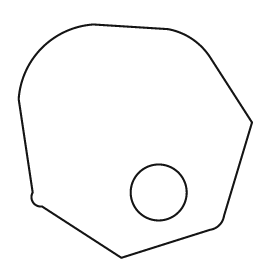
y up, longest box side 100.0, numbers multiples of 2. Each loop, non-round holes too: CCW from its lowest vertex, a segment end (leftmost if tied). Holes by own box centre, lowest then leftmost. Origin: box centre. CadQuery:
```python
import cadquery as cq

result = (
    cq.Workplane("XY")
    .moveTo(-6.0, -50.0)
    .lineTo(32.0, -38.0)
    .threePointArc((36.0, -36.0), (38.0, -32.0))
    .lineTo(50.0, 8.0)
    .lineTo(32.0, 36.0)
    .threePointArc((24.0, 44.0), (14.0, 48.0))
    .lineTo(-18.0, 50.0)
    .threePointArc((-40.0, 40.0), (-50.0, 18.0))
    .lineTo(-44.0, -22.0)
    .threePointArc((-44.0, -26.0), (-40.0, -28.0))
    .close()
    .moveTo(10.0, -22.0)
    .circle(12.0)
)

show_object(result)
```